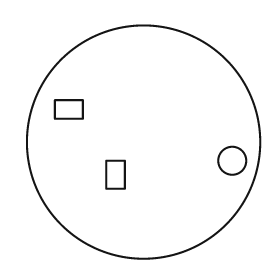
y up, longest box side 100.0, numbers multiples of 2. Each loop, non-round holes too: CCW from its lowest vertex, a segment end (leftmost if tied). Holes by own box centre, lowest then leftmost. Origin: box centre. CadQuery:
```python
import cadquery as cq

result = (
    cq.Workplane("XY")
    .moveTo(0.0, 0.0)
    .circle(50.0)
    .moveTo(-16.0, -20.0)
    .lineTo(-8.0, -20.0)
    .lineTo(-8.0, -8.0)
    .lineTo(-16.0, -8.0)
    .close()
    .moveTo(38.0, -8.0)
    .circle(6.0)
    .moveTo(-38.0, 10.0)
    .lineTo(-26.0, 10.0)
    .lineTo(-26.0, 18.0)
    .lineTo(-38.0, 18.0)
    .close()
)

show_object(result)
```